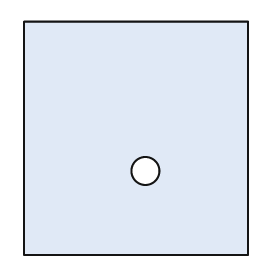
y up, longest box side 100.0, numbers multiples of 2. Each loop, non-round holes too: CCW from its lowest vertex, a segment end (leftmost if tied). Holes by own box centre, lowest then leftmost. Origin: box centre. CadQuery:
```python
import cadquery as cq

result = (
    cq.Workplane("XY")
    .moveTo(-48.0, -50.0)
    .lineTo(48.0, -50.0)
    .lineTo(48.0, 50.0)
    .lineTo(-48.0, 50.0)
    .close()
    .moveTo(4.0, -14.0)
    .circle(6.0)
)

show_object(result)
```